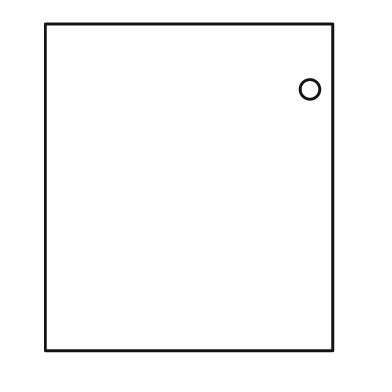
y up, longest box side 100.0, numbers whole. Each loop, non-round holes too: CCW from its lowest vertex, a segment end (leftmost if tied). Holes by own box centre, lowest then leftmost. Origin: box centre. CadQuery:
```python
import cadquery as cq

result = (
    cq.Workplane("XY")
    .moveTo(-44.0, -50.0)
    .lineTo(44.0, -50.0)
    .lineTo(44.0, 50.0)
    .lineTo(-44.0, 50.0)
    .close()
    .moveTo(37.0, 30.0)
    .circle(3.0)
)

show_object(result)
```